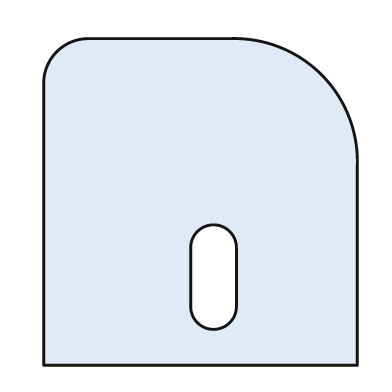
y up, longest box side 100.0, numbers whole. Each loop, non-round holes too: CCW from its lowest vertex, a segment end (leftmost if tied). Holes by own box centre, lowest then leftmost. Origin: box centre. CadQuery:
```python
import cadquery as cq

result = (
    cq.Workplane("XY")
    .moveTo(-48.0, -50.0)
    .lineTo(48.0, -50.0)
    .lineTo(48.0, 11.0)
    .threePointArc((37.0, 39.0), (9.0, 50.0))
    .lineTo(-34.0, 50.0)
    .threePointArc((-44.0, 46.0), (-48.0, 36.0))
    .close()
    .moveTo(-3.0, -32.0)
    .threePointArc((4.0, -39.0), (11.0, -32.0))
    .lineTo(11.0, -14.0)
    .threePointArc((4.0, -7.0), (-3.0, -14.0))
    .close()
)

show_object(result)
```